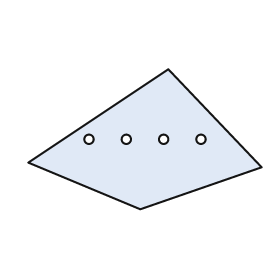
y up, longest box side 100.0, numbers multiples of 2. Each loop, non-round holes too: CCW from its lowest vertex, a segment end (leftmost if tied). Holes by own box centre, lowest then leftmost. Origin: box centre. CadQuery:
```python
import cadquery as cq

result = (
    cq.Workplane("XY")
    .moveTo(-2.0, -30.0)
    .lineTo(50.0, -12.0)
    .lineTo(10.0, 30.0)
    .lineTo(-50.0, -10.0)
    .close()
    .moveTo(-24.0, 0.0)
    .circle(2.0)
    .moveTo(-8.0, 0.0)
    .circle(2.0)
    .moveTo(8.0, 0.0)
    .circle(2.0)
    .moveTo(24.0, 0.0)
    .circle(2.0)
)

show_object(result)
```